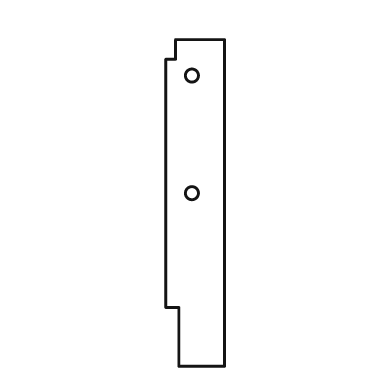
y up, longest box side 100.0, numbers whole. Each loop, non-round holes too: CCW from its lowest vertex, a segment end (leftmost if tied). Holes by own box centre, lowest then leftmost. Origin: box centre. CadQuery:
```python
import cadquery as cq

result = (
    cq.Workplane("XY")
    .moveTo(-5.0, -50.0)
    .lineTo(9.0, -50.0)
    .lineTo(9.0, 50.0)
    .lineTo(-6.0, 50.0)
    .lineTo(-6.0, 44.0)
    .lineTo(-9.0, 44.0)
    .lineTo(-9.0, -32.0)
    .lineTo(-5.0, -32.0)
    .close()
    .moveTo(-1.0, 3.0)
    .circle(2.0)
    .moveTo(-1.0, 39.0)
    .circle(2.0)
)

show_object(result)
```